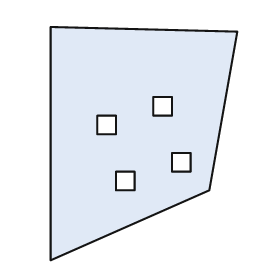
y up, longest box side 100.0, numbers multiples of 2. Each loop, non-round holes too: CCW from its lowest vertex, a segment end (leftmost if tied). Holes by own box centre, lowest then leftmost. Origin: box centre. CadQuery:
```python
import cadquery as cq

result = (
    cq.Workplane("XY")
    .moveTo(-40.0, -50.0)
    .lineTo(28.0, -20.0)
    .lineTo(40.0, 48.0)
    .lineTo(-40.0, 50.0)
    .close()
    .moveTo(-12.0, -20.0)
    .lineTo(-4.0, -20.0)
    .lineTo(-4.0, -12.0)
    .lineTo(-12.0, -12.0)
    .close()
    .moveTo(12.0, -12.0)
    .lineTo(20.0, -12.0)
    .lineTo(20.0, -4.0)
    .lineTo(12.0, -4.0)
    .close()
    .moveTo(-20.0, 4.0)
    .lineTo(-12.0, 4.0)
    .lineTo(-12.0, 12.0)
    .lineTo(-20.0, 12.0)
    .close()
    .moveTo(4.0, 12.0)
    .lineTo(12.0, 12.0)
    .lineTo(12.0, 20.0)
    .lineTo(4.0, 20.0)
    .close()
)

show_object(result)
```